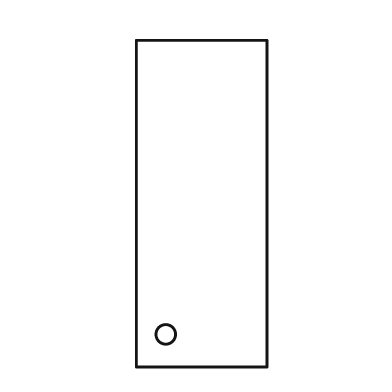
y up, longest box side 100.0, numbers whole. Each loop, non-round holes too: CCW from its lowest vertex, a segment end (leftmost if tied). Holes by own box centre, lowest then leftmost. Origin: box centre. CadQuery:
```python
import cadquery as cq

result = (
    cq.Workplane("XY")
    .moveTo(-20.0, -50.0)
    .lineTo(20.0, -50.0)
    .lineTo(20.0, 50.0)
    .lineTo(-20.0, 50.0)
    .close()
    .moveTo(-11.0, -40.0)
    .circle(3.0)
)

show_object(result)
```